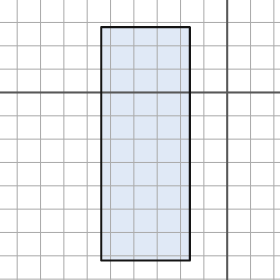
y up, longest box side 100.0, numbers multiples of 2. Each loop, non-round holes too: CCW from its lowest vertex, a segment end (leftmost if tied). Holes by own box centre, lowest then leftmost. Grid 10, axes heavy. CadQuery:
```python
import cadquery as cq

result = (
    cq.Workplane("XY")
    .moveTo(-54.0, -72.0)
    .lineTo(-16.0, -72.0)
    .lineTo(-16.0, 28.0)
    .lineTo(-54.0, 28.0)
    .close()
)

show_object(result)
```